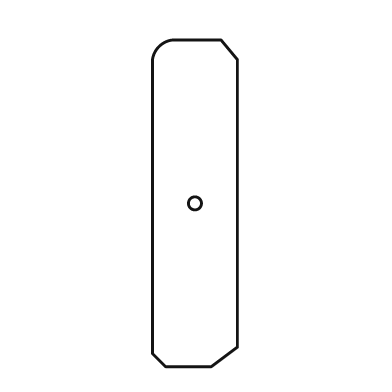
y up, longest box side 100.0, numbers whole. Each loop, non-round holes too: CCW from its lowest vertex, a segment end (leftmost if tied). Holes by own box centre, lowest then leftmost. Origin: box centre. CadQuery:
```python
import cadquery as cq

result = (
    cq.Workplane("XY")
    .moveTo(-9.0, -50.0)
    .lineTo(5.0, -50.0)
    .lineTo(13.0, -44.0)
    .lineTo(13.0, 44.0)
    .lineTo(8.0, 50.0)
    .lineTo(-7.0, 50.0)
    .threePointArc((-11.0, 48.0), (-13.0, 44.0))
    .lineTo(-13.0, -46.0)
    .close()
    .moveTo(0.0, 0.0)
    .circle(2.0)
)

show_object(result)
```